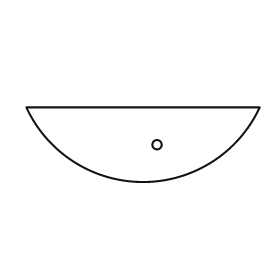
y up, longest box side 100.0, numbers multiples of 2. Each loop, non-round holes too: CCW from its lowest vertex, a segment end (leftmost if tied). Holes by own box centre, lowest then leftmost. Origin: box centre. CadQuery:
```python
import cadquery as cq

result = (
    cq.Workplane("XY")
    .moveTo(-50.0, 16.0)
    .threePointArc((0.0, -16.0), (50.0, 16.0))
    .close()
    .moveTo(6.0, 0.0)
    .circle(2.0)
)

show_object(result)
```